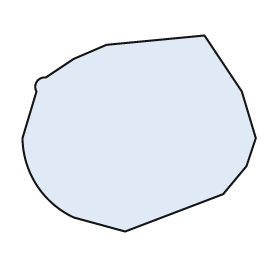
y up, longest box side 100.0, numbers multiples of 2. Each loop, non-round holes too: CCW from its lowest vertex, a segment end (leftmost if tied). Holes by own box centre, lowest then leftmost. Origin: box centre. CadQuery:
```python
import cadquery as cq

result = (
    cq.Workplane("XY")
    .moveTo(-6.0, -42.0)
    .lineTo(36.0, -26.0)
    .lineTo(46.0, -14.0)
    .lineTo(50.0, -2.0)
    .lineTo(44.0, 18.0)
    .lineTo(28.0, 42.0)
    .lineTo(-14.0, 38.0)
    .lineTo(-28.0, 32.0)
    .lineTo(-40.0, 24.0)
    .threePointArc((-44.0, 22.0), (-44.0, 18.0))
    .lineTo(-50.0, -2.0)
    .threePointArc((-44.0, -22.0), (-28.0, -36.0))
    .close()
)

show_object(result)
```